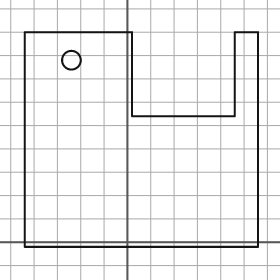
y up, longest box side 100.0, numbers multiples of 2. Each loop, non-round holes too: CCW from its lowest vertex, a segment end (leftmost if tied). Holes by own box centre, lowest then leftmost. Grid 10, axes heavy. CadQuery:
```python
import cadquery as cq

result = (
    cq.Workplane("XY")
    .moveTo(-44.0, -2.0)
    .lineTo(56.0, -2.0)
    .lineTo(56.0, 90.0)
    .lineTo(46.0, 90.0)
    .lineTo(46.0, 54.0)
    .lineTo(2.0, 54.0)
    .lineTo(2.0, 90.0)
    .lineTo(-44.0, 90.0)
    .close()
    .moveTo(-24.0, 78.0)
    .circle(4.0)
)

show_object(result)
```